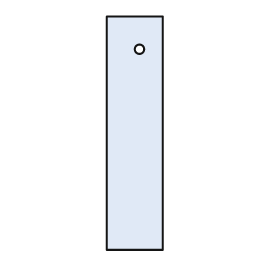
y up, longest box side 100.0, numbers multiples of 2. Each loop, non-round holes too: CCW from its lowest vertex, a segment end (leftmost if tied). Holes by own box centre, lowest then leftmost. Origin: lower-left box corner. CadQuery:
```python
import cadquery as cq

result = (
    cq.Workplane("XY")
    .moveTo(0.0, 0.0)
    .lineTo(24.0, 0.0)
    .lineTo(24.0, 100.0)
    .lineTo(0.0, 100.0)
    .close()
    .moveTo(14.0, 86.0)
    .circle(2.0)
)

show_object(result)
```